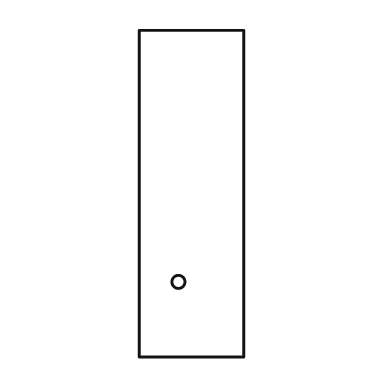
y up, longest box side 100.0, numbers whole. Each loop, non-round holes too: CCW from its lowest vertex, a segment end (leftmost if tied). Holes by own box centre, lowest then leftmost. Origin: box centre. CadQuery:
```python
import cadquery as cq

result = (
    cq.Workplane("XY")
    .moveTo(-16.0, -50.0)
    .lineTo(16.0, -50.0)
    .lineTo(16.0, 50.0)
    .lineTo(-16.0, 50.0)
    .close()
    .moveTo(-4.0, -27.0)
    .circle(2.0)
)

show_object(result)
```